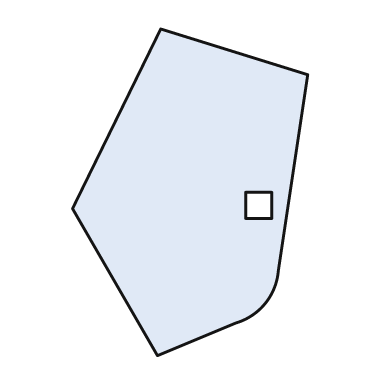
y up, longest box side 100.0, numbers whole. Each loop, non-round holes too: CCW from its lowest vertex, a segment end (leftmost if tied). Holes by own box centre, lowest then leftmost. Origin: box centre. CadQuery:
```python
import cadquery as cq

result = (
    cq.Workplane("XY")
    .moveTo(-10.0, -50.0)
    .lineTo(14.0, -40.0)
    .threePointArc((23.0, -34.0), (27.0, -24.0))
    .lineTo(36.0, 36.0)
    .lineTo(-9.0, 50.0)
    .lineTo(-36.0, -5.0)
    .close()
    .moveTo(17.0, -8.0)
    .lineTo(25.0, -8.0)
    .lineTo(25.0, 0.0)
    .lineTo(17.0, 0.0)
    .close()
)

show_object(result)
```